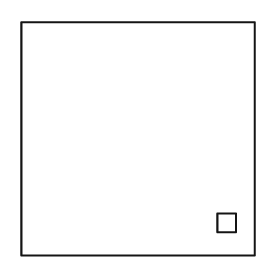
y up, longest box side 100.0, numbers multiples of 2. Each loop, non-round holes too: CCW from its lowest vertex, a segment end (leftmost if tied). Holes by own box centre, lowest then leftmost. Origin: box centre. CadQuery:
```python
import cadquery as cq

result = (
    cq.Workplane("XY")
    .moveTo(-50.0, -50.0)
    .lineTo(50.0, -50.0)
    .lineTo(50.0, 50.0)
    .lineTo(-50.0, 50.0)
    .close()
    .moveTo(34.0, -40.0)
    .lineTo(42.0, -40.0)
    .lineTo(42.0, -32.0)
    .lineTo(34.0, -32.0)
    .close()
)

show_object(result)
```